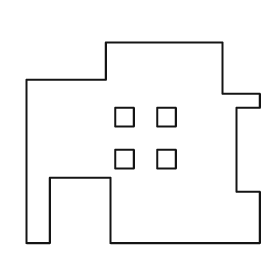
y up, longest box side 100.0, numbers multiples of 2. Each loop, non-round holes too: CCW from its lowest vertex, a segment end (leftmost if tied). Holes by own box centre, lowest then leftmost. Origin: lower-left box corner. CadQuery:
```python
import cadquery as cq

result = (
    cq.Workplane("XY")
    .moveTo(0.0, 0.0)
    .lineTo(10.0, 0.0)
    .lineTo(10.0, 28.0)
    .lineTo(36.0, 28.0)
    .lineTo(36.0, 0.0)
    .lineTo(100.0, 0.0)
    .lineTo(100.0, 22.0)
    .lineTo(90.0, 22.0)
    .lineTo(90.0, 58.0)
    .lineTo(100.0, 58.0)
    .lineTo(100.0, 64.0)
    .lineTo(84.0, 64.0)
    .lineTo(84.0, 86.0)
    .lineTo(34.0, 86.0)
    .lineTo(34.0, 70.0)
    .lineTo(0.0, 70.0)
    .close()
    .moveTo(38.0, 32.0)
    .lineTo(46.0, 32.0)
    .lineTo(46.0, 40.0)
    .lineTo(38.0, 40.0)
    .close()
    .moveTo(56.0, 32.0)
    .lineTo(64.0, 32.0)
    .lineTo(64.0, 40.0)
    .lineTo(56.0, 40.0)
    .close()
    .moveTo(38.0, 50.0)
    .lineTo(46.0, 50.0)
    .lineTo(46.0, 58.0)
    .lineTo(38.0, 58.0)
    .close()
    .moveTo(56.0, 50.0)
    .lineTo(64.0, 50.0)
    .lineTo(64.0, 58.0)
    .lineTo(56.0, 58.0)
    .close()
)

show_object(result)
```